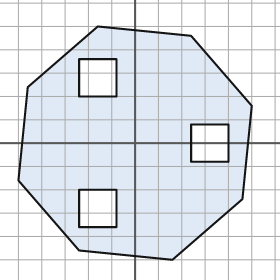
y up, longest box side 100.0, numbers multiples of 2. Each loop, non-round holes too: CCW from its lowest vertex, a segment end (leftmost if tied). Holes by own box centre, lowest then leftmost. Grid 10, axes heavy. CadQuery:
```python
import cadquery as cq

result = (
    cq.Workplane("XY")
    .moveTo(16.0, -50.0)
    .lineTo(46.0, -24.0)
    .lineTo(50.0, 16.0)
    .lineTo(24.0, 46.0)
    .lineTo(-16.0, 50.0)
    .lineTo(-46.0, 24.0)
    .lineTo(-50.0, -16.0)
    .lineTo(-24.0, -46.0)
    .close()
    .moveTo(-24.0, -36.0)
    .lineTo(-8.0, -36.0)
    .lineTo(-8.0, -20.0)
    .lineTo(-24.0, -20.0)
    .close()
    .moveTo(24.0, -8.0)
    .lineTo(40.0, -8.0)
    .lineTo(40.0, 8.0)
    .lineTo(24.0, 8.0)
    .close()
    .moveTo(-24.0, 20.0)
    .lineTo(-8.0, 20.0)
    .lineTo(-8.0, 36.0)
    .lineTo(-24.0, 36.0)
    .close()
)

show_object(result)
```